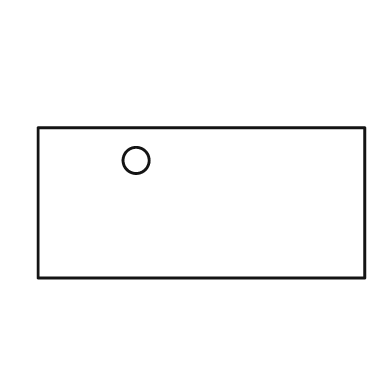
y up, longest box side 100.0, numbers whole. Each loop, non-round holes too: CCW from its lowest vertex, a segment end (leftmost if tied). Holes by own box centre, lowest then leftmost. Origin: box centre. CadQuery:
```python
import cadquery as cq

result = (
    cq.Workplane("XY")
    .moveTo(-50.0, -23.0)
    .lineTo(50.0, -23.0)
    .lineTo(50.0, 23.0)
    .lineTo(-50.0, 23.0)
    .close()
    .moveTo(-20.0, 13.0)
    .circle(4.0)
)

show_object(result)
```